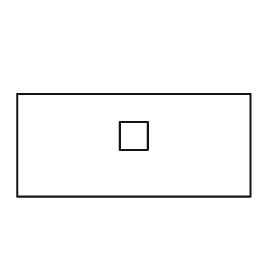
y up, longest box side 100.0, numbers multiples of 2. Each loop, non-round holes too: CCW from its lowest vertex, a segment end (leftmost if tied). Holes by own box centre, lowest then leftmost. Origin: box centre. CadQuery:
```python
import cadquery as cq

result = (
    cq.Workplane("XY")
    .moveTo(-50.0, -22.0)
    .lineTo(50.0, -22.0)
    .lineTo(50.0, 22.0)
    .lineTo(-50.0, 22.0)
    .close()
    .moveTo(-6.0, -2.0)
    .lineTo(6.0, -2.0)
    .lineTo(6.0, 10.0)
    .lineTo(-6.0, 10.0)
    .close()
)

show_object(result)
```